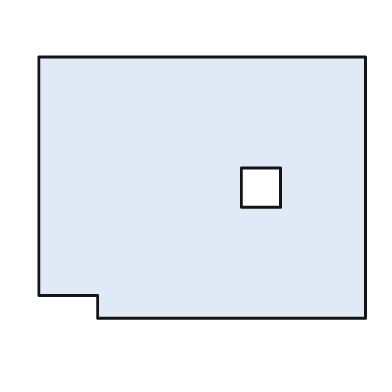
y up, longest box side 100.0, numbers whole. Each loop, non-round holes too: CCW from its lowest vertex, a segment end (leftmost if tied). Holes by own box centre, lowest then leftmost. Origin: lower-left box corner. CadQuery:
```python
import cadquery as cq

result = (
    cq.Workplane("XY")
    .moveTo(18.0, 0.0)
    .lineTo(100.0, 0.0)
    .lineTo(100.0, 80.0)
    .lineTo(0.0, 80.0)
    .lineTo(0.0, 7.0)
    .lineTo(18.0, 7.0)
    .close()
    .moveTo(62.0, 34.0)
    .lineTo(74.0, 34.0)
    .lineTo(74.0, 46.0)
    .lineTo(62.0, 46.0)
    .close()
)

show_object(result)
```